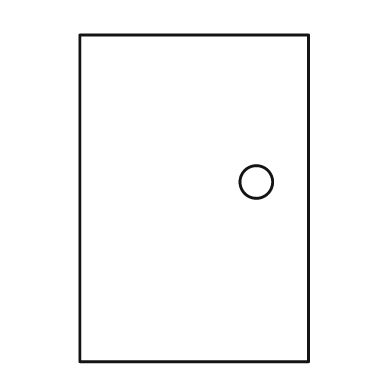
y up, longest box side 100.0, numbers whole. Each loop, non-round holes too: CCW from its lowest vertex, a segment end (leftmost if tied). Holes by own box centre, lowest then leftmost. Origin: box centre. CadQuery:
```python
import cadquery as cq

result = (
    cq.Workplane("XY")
    .moveTo(-35.0, -50.0)
    .lineTo(35.0, -50.0)
    .lineTo(35.0, 50.0)
    .lineTo(-35.0, 50.0)
    .close()
    .moveTo(19.0, 5.0)
    .circle(5.0)
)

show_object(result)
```